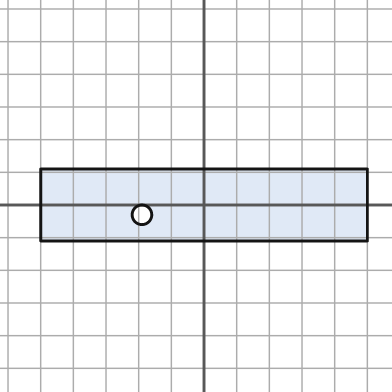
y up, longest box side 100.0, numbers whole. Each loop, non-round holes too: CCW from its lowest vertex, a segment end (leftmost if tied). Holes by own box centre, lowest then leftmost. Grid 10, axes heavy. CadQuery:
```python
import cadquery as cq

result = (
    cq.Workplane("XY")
    .moveTo(-50.0, -11.0)
    .lineTo(50.0, -11.0)
    .lineTo(50.0, 11.0)
    .lineTo(-50.0, 11.0)
    .close()
    .moveTo(-19.0, -3.0)
    .circle(3.0)
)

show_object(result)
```